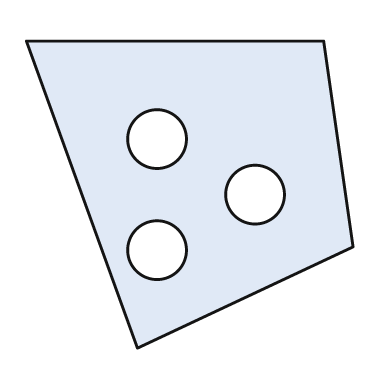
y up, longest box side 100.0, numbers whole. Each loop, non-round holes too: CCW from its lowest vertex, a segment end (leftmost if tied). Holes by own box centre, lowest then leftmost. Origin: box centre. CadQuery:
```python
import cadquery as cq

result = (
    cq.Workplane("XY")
    .moveTo(-16.0, -47.0)
    .lineTo(50.0, -16.0)
    .lineTo(41.0, 47.0)
    .lineTo(-50.0, 47.0)
    .close()
    .moveTo(-10.0, -17.0)
    .circle(9.0)
    .moveTo(20.0, 0.0)
    .circle(9.0)
    .moveTo(-10.0, 17.0)
    .circle(9.0)
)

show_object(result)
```